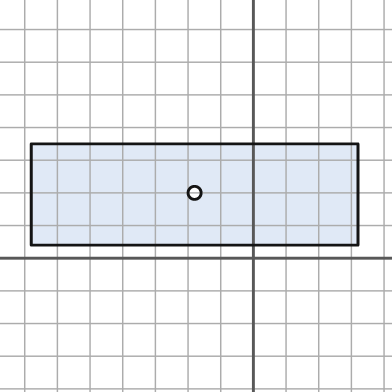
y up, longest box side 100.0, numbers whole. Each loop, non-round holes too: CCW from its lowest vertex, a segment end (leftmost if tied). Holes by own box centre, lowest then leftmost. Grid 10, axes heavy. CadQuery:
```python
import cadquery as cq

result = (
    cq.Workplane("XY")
    .moveTo(-68.0, 4.0)
    .lineTo(32.0, 4.0)
    .lineTo(32.0, 35.0)
    .lineTo(-68.0, 35.0)
    .close()
    .moveTo(-18.0, 20.0)
    .circle(2.0)
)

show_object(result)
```